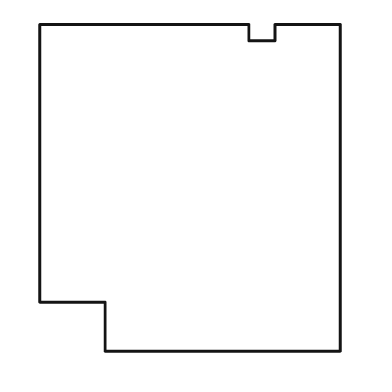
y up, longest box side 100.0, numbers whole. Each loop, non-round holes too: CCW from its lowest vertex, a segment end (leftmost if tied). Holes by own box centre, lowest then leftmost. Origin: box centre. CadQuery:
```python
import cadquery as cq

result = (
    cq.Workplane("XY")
    .moveTo(-26.0, -50.0)
    .lineTo(46.0, -50.0)
    .lineTo(46.0, 50.0)
    .lineTo(26.0, 50.0)
    .lineTo(26.0, 45.0)
    .lineTo(18.0, 45.0)
    .lineTo(18.0, 50.0)
    .lineTo(-46.0, 50.0)
    .lineTo(-46.0, -35.0)
    .lineTo(-26.0, -35.0)
    .close()
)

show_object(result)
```